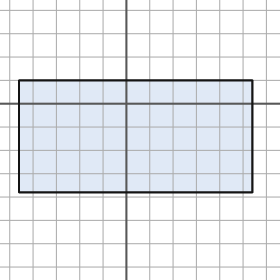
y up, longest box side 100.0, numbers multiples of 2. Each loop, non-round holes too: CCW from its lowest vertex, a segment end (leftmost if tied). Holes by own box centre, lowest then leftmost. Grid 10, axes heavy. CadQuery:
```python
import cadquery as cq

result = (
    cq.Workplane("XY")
    .moveTo(-46.0, -38.0)
    .lineTo(54.0, -38.0)
    .lineTo(54.0, 10.0)
    .lineTo(-46.0, 10.0)
    .close()
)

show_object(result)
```